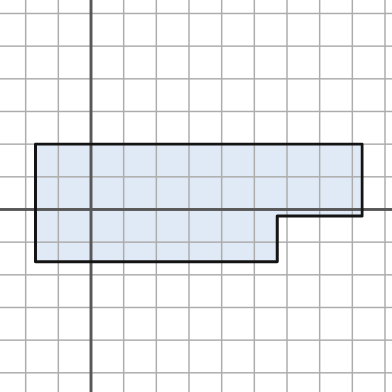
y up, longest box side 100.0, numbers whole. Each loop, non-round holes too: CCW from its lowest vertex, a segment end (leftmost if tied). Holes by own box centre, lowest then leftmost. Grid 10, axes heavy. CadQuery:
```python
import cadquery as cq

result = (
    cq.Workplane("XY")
    .moveTo(-17.0, -16.0)
    .lineTo(57.0, -16.0)
    .lineTo(57.0, -2.0)
    .lineTo(83.0, -2.0)
    .lineTo(83.0, 20.0)
    .lineTo(-17.0, 20.0)
    .close()
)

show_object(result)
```